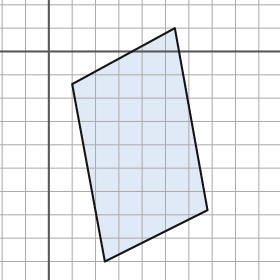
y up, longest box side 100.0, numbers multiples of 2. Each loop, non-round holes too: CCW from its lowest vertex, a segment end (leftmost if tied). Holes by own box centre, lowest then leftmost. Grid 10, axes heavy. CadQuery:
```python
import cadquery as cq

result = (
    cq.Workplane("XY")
    .moveTo(24.0, -90.0)
    .lineTo(68.0, -68.0)
    .lineTo(54.0, 10.0)
    .lineTo(10.0, -14.0)
    .close()
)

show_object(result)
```